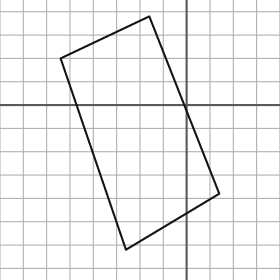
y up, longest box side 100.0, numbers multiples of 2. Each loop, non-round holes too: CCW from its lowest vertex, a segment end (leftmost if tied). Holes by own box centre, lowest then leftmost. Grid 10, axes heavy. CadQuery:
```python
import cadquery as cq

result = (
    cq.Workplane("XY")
    .moveTo(-26.0, -62.0)
    .lineTo(14.0, -38.0)
    .lineTo(-16.0, 38.0)
    .lineTo(-54.0, 20.0)
    .close()
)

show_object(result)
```